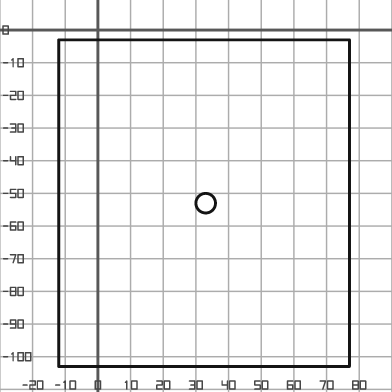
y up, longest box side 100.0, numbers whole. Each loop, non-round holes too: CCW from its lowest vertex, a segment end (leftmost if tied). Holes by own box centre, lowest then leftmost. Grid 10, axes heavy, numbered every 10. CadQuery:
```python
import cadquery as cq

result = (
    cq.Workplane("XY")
    .moveTo(-12.0, -103.0)
    .lineTo(77.0, -103.0)
    .lineTo(77.0, -3.0)
    .lineTo(-12.0, -3.0)
    .close()
    .moveTo(33.0, -53.0)
    .circle(3.0)
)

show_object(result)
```